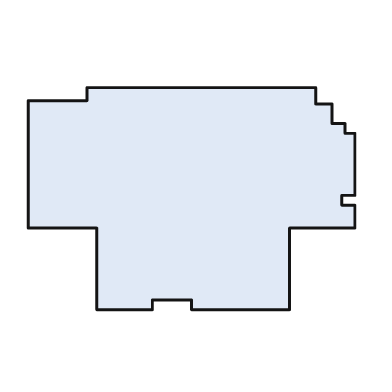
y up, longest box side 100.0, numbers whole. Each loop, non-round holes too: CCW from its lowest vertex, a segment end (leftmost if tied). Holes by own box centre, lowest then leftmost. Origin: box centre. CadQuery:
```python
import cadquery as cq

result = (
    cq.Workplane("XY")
    .moveTo(-29.0, -34.0)
    .lineTo(-12.0, -34.0)
    .lineTo(-12.0, -31.0)
    .lineTo(0.0, -31.0)
    .lineTo(0.0, -34.0)
    .lineTo(30.0, -34.0)
    .lineTo(30.0, -9.0)
    .lineTo(50.0, -9.0)
    .lineTo(50.0, -2.0)
    .lineTo(46.0, -2.0)
    .lineTo(46.0, 1.0)
    .lineTo(50.0, 1.0)
    .lineTo(50.0, 20.0)
    .lineTo(47.0, 20.0)
    .lineTo(47.0, 23.0)
    .lineTo(43.0, 23.0)
    .lineTo(43.0, 29.0)
    .lineTo(38.0, 29.0)
    .lineTo(38.0, 34.0)
    .lineTo(-32.0, 34.0)
    .lineTo(-32.0, 30.0)
    .lineTo(-50.0, 30.0)
    .lineTo(-50.0, -9.0)
    .lineTo(-29.0, -9.0)
    .close()
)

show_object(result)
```